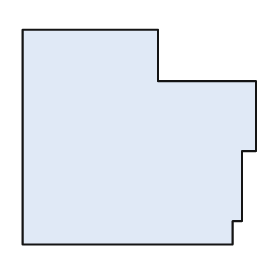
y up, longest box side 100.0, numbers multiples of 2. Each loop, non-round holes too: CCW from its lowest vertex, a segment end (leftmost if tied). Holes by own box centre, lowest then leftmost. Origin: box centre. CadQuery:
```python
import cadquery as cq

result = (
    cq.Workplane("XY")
    .moveTo(-50.0, -46.0)
    .lineTo(40.0, -46.0)
    .lineTo(40.0, -36.0)
    .lineTo(44.0, -36.0)
    .lineTo(44.0, -6.0)
    .lineTo(50.0, -6.0)
    .lineTo(50.0, 24.0)
    .lineTo(8.0, 24.0)
    .lineTo(8.0, 46.0)
    .lineTo(-50.0, 46.0)
    .close()
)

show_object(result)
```